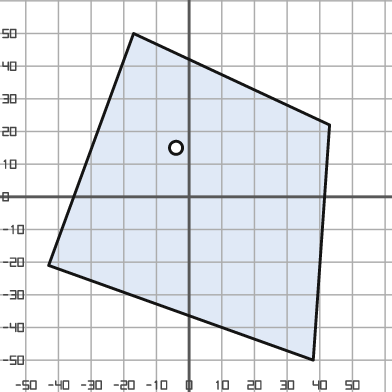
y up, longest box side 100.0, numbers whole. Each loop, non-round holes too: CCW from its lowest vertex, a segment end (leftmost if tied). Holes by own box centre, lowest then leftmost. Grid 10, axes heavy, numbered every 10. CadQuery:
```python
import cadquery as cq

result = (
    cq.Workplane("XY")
    .moveTo(38.0, -50.0)
    .lineTo(43.0, 22.0)
    .lineTo(-17.0, 50.0)
    .lineTo(-43.0, -21.0)
    .close()
    .moveTo(-4.0, 15.0)
    .circle(2.0)
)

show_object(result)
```